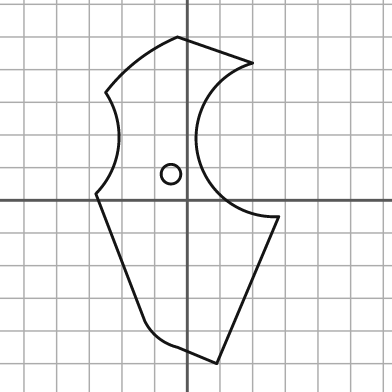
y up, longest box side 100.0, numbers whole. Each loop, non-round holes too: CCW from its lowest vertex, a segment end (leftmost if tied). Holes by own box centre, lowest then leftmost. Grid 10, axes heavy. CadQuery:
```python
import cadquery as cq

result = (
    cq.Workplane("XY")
    .moveTo(9.0, -50.0)
    .lineTo(28.0, -5.0)
    .threePointArc((3.0, 15.0), (20.0, 42.0))
    .lineTo(-3.0, 50.0)
    .threePointArc((-15.0, 43.0), (-25.0, 33.0))
    .threePointArc((-21.0, 17.0), (-28.0, 2.0))
    .lineTo(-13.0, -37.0)
    .threePointArc((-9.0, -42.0), (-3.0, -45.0))
    .close()
    .moveTo(-5.0, 8.0)
    .circle(3.0)
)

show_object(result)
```